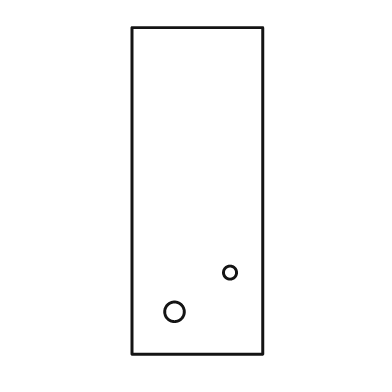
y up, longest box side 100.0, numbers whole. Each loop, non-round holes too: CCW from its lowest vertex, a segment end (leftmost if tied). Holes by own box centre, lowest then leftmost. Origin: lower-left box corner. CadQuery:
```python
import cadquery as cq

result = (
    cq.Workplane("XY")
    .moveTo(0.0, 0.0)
    .lineTo(40.0, 0.0)
    .lineTo(40.0, 100.0)
    .lineTo(0.0, 100.0)
    .close()
    .moveTo(13.0, 13.0)
    .circle(3.0)
    .moveTo(30.0, 25.0)
    .circle(2.0)
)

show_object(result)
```